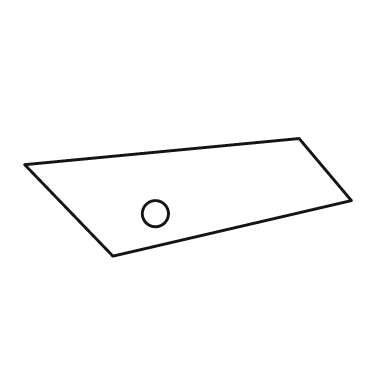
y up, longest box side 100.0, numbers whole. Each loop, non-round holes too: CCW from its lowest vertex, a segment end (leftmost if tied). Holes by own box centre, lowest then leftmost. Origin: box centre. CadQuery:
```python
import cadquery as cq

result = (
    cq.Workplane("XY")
    .moveTo(-23.0, -18.0)
    .lineTo(50.0, -1.0)
    .lineTo(34.0, 18.0)
    .lineTo(-50.0, 10.0)
    .close()
    .moveTo(-10.0, -5.0)
    .circle(4.0)
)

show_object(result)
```